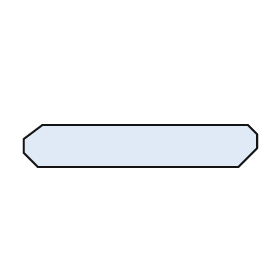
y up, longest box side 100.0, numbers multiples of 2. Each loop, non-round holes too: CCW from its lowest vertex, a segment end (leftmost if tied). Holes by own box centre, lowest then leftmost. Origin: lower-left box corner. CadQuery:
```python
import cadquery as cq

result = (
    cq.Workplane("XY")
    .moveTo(6.0, 0.0)
    .lineTo(92.0, 0.0)
    .lineTo(100.0, 8.0)
    .lineTo(100.0, 14.0)
    .lineTo(96.0, 18.0)
    .lineTo(8.0, 18.0)
    .lineTo(0.0, 12.0)
    .lineTo(0.0, 6.0)
    .close()
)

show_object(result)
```